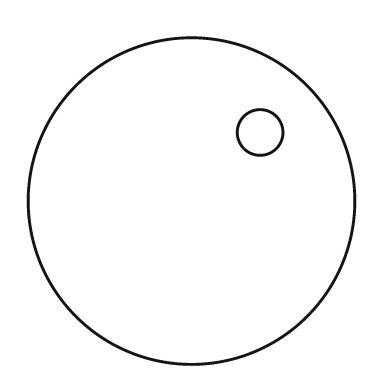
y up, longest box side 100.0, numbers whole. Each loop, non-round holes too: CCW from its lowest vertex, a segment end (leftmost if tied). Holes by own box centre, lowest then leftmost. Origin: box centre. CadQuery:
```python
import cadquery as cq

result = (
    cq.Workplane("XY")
    .moveTo(0.0, 0.0)
    .circle(50.0)
    .moveTo(21.0, 21.0)
    .circle(7.0)
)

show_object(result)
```